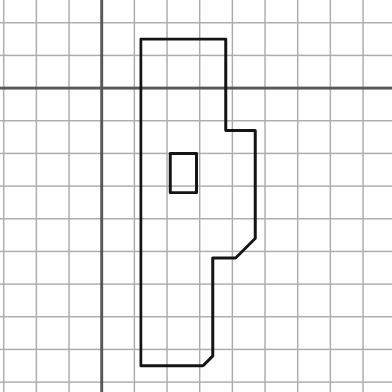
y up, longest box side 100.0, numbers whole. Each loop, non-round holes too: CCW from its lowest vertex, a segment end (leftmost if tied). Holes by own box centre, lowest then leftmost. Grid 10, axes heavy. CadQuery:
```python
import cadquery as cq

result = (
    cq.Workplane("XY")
    .moveTo(12.0, -85.0)
    .lineTo(31.0, -85.0)
    .lineTo(34.0, -82.0)
    .lineTo(34.0, -52.0)
    .lineTo(41.0, -52.0)
    .lineTo(47.0, -46.0)
    .lineTo(47.0, -13.0)
    .lineTo(38.0, -13.0)
    .lineTo(38.0, 15.0)
    .lineTo(12.0, 15.0)
    .close()
    .moveTo(21.0, -32.0)
    .lineTo(29.0, -32.0)
    .lineTo(29.0, -20.0)
    .lineTo(21.0, -20.0)
    .close()
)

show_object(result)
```